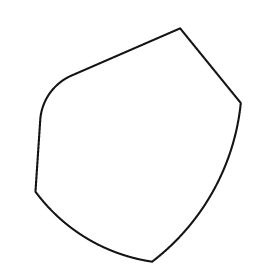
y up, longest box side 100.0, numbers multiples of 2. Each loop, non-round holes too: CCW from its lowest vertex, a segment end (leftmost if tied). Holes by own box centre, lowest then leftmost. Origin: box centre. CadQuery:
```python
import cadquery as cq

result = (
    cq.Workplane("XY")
    .moveTo(6.0, -50.0)
    .threePointArc((32.0, -20.0), (44.0, 18.0))
    .lineTo(18.0, 50.0)
    .lineTo(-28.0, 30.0)
    .threePointArc((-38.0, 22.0), (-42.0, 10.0))
    .lineTo(-44.0, -20.0)
    .threePointArc((-22.0, -40.0), (6.0, -50.0))
    .close()
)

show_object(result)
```